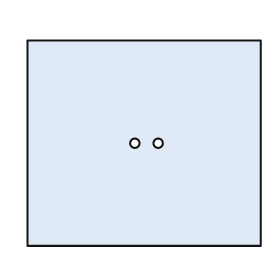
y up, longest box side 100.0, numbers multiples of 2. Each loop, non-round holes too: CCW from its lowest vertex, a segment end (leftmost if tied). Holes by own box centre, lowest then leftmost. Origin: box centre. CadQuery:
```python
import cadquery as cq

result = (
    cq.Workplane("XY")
    .moveTo(-50.0, -44.0)
    .lineTo(50.0, -44.0)
    .lineTo(50.0, 44.0)
    .lineTo(-50.0, 44.0)
    .close()
    .moveTo(-4.0, 0.0)
    .circle(2.0)
    .moveTo(6.0, 0.0)
    .circle(2.0)
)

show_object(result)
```